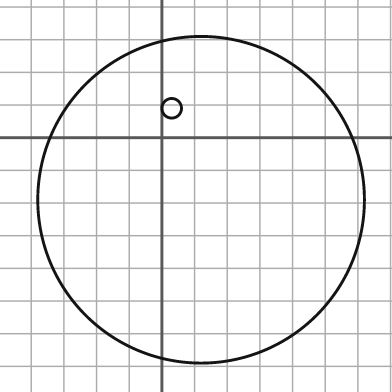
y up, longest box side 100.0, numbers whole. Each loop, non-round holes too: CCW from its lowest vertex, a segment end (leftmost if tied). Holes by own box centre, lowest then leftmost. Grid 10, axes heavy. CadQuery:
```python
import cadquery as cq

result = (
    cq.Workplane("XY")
    .moveTo(12.0, -19.0)
    .circle(50.0)
    .moveTo(3.0, 9.0)
    .circle(3.0)
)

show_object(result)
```